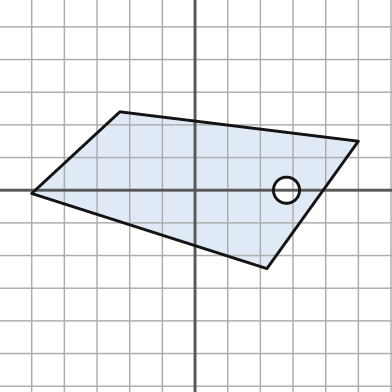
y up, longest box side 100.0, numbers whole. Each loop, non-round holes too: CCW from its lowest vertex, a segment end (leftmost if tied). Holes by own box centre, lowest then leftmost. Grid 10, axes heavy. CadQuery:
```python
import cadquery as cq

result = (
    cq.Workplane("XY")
    .moveTo(22.0, -24.0)
    .lineTo(50.0, 15.0)
    .lineTo(-23.0, 24.0)
    .lineTo(-50.0, -1.0)
    .close()
    .moveTo(28.0, 0.0)
    .circle(4.0)
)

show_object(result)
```